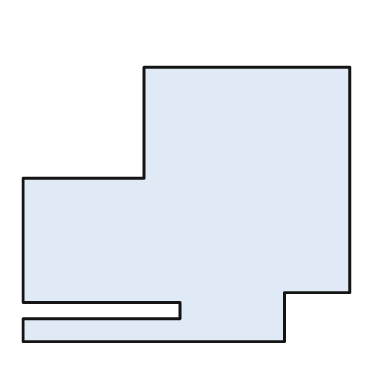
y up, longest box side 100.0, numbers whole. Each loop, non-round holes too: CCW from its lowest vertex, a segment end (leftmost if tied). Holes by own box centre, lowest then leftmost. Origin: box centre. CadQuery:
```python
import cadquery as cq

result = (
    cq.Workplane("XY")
    .moveTo(-50.0, -42.0)
    .lineTo(30.0, -42.0)
    .lineTo(30.0, -27.0)
    .lineTo(50.0, -27.0)
    .lineTo(50.0, 42.0)
    .lineTo(-13.0, 42.0)
    .lineTo(-13.0, 8.0)
    .lineTo(-50.0, 8.0)
    .lineTo(-50.0, -30.0)
    .lineTo(-2.0, -30.0)
    .lineTo(-2.0, -35.0)
    .lineTo(-50.0, -35.0)
    .close()
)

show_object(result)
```